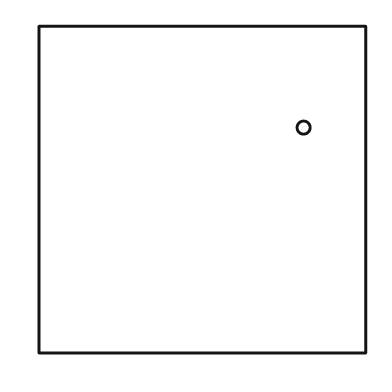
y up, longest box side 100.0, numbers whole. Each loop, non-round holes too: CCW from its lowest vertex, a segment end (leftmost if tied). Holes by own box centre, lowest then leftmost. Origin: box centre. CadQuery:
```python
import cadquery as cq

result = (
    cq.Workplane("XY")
    .moveTo(-50.0, -50.0)
    .lineTo(50.0, -50.0)
    .lineTo(50.0, 50.0)
    .lineTo(-50.0, 50.0)
    .close()
    .moveTo(31.0, 19.0)
    .circle(2.0)
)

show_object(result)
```